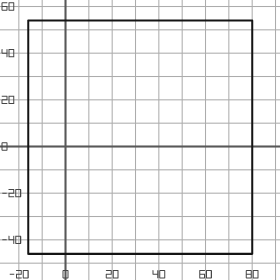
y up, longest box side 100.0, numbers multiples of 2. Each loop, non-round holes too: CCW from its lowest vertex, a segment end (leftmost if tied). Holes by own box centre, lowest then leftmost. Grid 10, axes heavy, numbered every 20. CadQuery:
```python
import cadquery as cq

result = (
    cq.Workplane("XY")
    .moveTo(-16.0, -46.0)
    .lineTo(80.0, -46.0)
    .lineTo(80.0, 54.0)
    .lineTo(-16.0, 54.0)
    .close()
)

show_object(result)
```